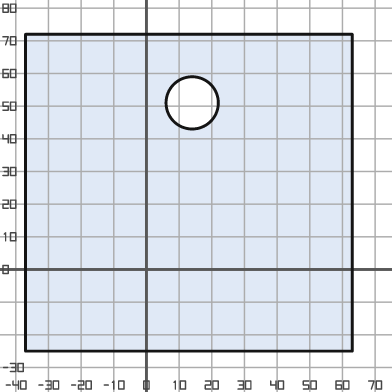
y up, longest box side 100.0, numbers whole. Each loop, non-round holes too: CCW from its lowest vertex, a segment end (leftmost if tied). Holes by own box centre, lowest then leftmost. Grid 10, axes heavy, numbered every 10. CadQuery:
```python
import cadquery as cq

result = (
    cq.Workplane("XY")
    .moveTo(-37.0, -25.0)
    .lineTo(63.0, -25.0)
    .lineTo(63.0, 72.0)
    .lineTo(-37.0, 72.0)
    .close()
    .moveTo(14.0, 51.0)
    .circle(8.0)
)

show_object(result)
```